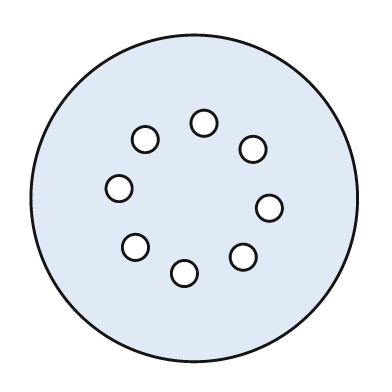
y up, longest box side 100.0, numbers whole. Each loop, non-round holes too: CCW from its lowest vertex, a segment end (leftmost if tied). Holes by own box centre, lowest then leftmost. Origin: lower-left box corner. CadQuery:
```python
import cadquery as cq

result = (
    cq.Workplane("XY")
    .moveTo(50.0, 50.0)
    .circle(50.0)
    .moveTo(47.0, 27.0)
    .circle(4.0)
    .moveTo(65.0, 32.0)
    .circle(4.0)
    .moveTo(32.0, 35.0)
    .circle(4.0)
    .moveTo(73.0, 47.0)
    .circle(4.0)
    .moveTo(27.0, 53.0)
    .circle(4.0)
    .moveTo(68.0, 65.0)
    .circle(4.0)
    .moveTo(35.0, 68.0)
    .circle(4.0)
    .moveTo(53.0, 73.0)
    .circle(4.0)
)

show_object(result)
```